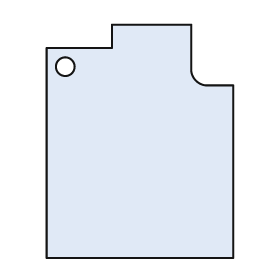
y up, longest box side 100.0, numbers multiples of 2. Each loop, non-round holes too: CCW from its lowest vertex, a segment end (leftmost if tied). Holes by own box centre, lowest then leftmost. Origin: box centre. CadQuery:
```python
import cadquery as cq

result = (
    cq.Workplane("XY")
    .moveTo(-40.0, -50.0)
    .lineTo(40.0, -50.0)
    .lineTo(40.0, 24.0)
    .lineTo(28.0, 24.0)
    .threePointArc((24.0, 26.0), (22.0, 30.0))
    .lineTo(22.0, 50.0)
    .lineTo(-12.0, 50.0)
    .lineTo(-12.0, 40.0)
    .lineTo(-40.0, 40.0)
    .close()
    .moveTo(-32.0, 32.0)
    .circle(4.0)
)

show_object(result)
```